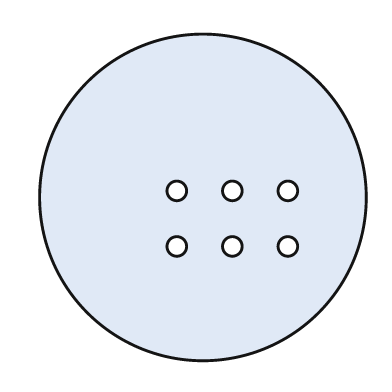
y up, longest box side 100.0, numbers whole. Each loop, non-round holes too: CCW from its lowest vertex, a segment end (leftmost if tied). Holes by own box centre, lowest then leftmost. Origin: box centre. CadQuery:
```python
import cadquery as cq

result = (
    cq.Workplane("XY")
    .moveTo(0.0, 0.0)
    .circle(50.0)
    .moveTo(-8.0, -15.0)
    .circle(3.0)
    .moveTo(9.0, -15.0)
    .circle(3.0)
    .moveTo(26.0, -15.0)
    .circle(3.0)
    .moveTo(-8.0, 2.0)
    .circle(3.0)
    .moveTo(9.0, 2.0)
    .circle(3.0)
    .moveTo(26.0, 2.0)
    .circle(3.0)
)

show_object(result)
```